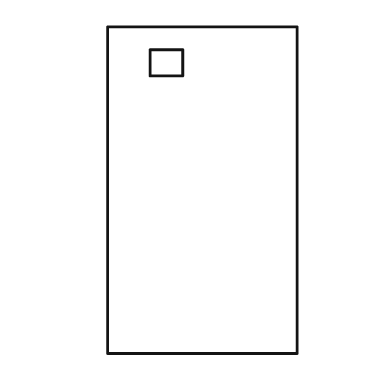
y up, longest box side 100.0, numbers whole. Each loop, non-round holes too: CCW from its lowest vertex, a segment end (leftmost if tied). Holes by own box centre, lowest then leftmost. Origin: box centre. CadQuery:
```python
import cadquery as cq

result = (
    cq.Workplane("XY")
    .moveTo(-29.0, -50.0)
    .lineTo(29.0, -50.0)
    .lineTo(29.0, 50.0)
    .lineTo(-29.0, 50.0)
    .close()
    .moveTo(-16.0, 35.0)
    .lineTo(-6.0, 35.0)
    .lineTo(-6.0, 43.0)
    .lineTo(-16.0, 43.0)
    .close()
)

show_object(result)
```